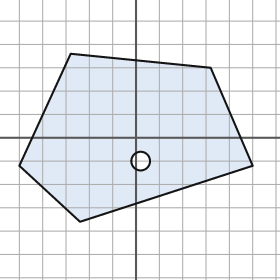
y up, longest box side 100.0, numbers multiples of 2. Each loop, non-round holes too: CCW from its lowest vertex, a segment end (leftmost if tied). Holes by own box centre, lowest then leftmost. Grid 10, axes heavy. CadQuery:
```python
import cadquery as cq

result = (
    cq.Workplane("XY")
    .moveTo(-24.0, -36.0)
    .lineTo(50.0, -12.0)
    .lineTo(32.0, 30.0)
    .lineTo(-28.0, 36.0)
    .lineTo(-50.0, -12.0)
    .close()
    .moveTo(2.0, -10.0)
    .circle(4.0)
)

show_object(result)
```